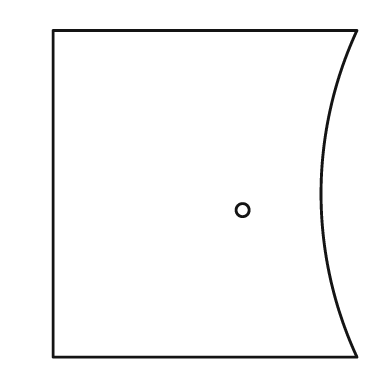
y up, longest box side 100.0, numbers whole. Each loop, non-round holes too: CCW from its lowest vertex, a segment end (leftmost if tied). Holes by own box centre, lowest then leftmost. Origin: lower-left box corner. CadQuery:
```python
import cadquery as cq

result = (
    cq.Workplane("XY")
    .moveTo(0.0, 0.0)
    .lineTo(93.0, 0.0)
    .threePointArc((82.0, 50.0), (93.0, 100.0))
    .lineTo(0.0, 100.0)
    .close()
    .moveTo(58.0, 45.0)
    .circle(2.0)
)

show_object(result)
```